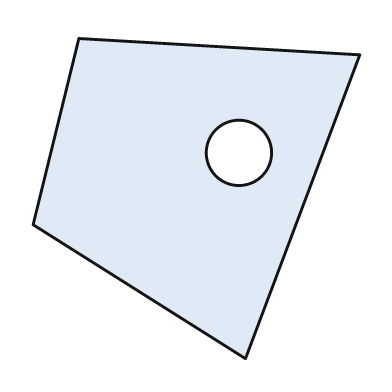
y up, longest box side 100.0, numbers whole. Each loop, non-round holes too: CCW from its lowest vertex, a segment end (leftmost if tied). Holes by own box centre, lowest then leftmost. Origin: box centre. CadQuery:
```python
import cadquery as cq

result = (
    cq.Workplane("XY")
    .moveTo(15.0, -49.0)
    .lineTo(50.0, 44.0)
    .lineTo(-36.0, 49.0)
    .lineTo(-50.0, -8.0)
    .close()
    .moveTo(13.0, 14.0)
    .circle(10.0)
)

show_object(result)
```